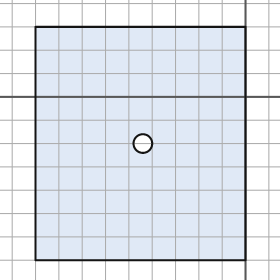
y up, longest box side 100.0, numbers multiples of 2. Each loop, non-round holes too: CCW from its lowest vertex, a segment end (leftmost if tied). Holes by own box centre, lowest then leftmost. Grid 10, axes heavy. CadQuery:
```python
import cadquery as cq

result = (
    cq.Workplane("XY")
    .moveTo(-90.0, -70.0)
    .lineTo(0.0, -70.0)
    .lineTo(0.0, 30.0)
    .lineTo(-90.0, 30.0)
    .close()
    .moveTo(-44.0, -20.0)
    .circle(4.0)
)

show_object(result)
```